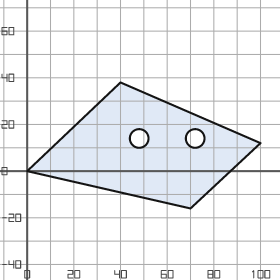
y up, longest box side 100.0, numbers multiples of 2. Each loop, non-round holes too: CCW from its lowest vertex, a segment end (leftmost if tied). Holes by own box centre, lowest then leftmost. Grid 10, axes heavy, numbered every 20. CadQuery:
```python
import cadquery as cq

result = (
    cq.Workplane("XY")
    .moveTo(70.0, -16.0)
    .lineTo(100.0, 12.0)
    .lineTo(40.0, 38.0)
    .lineTo(0.0, 0.0)
    .close()
    .moveTo(48.0, 14.0)
    .circle(4.0)
    .moveTo(72.0, 14.0)
    .circle(4.0)
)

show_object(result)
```